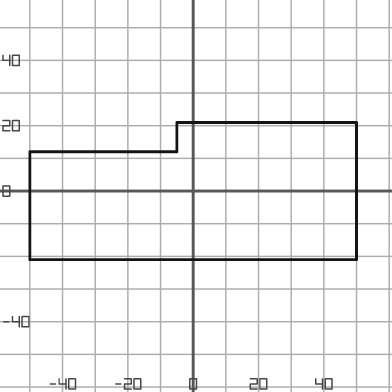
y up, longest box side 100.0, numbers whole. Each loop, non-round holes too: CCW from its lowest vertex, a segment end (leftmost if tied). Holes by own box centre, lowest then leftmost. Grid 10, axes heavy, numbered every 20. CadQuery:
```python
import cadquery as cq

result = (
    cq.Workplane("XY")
    .moveTo(-50.0, -21.0)
    .lineTo(50.0, -21.0)
    .lineTo(50.0, 21.0)
    .lineTo(-5.0, 21.0)
    .lineTo(-5.0, 12.0)
    .lineTo(-50.0, 12.0)
    .close()
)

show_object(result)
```